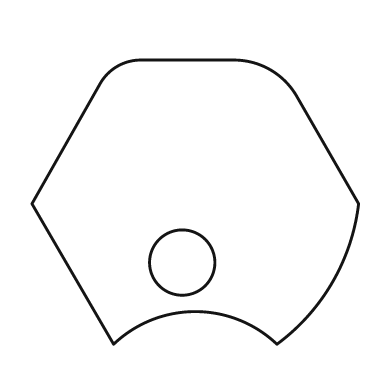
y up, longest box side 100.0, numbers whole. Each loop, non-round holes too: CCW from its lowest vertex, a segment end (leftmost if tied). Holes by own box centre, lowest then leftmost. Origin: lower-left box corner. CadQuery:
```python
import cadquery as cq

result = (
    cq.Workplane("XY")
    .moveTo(25.0, 0.0)
    .threePointArc((50.0, 10.0), (75.0, 0.0))
    .threePointArc((92.0, 19.0), (100.0, 43.0))
    .lineTo(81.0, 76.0)
    .threePointArc((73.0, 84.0), (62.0, 87.0))
    .lineTo(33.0, 87.0)
    .threePointArc((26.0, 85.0), (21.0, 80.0))
    .lineTo(0.0, 43.0)
    .close()
    .moveTo(46.0, 25.0)
    .circle(10.0)
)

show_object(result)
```